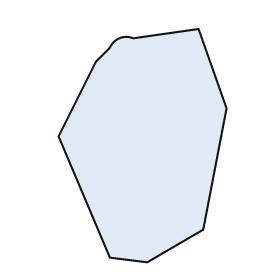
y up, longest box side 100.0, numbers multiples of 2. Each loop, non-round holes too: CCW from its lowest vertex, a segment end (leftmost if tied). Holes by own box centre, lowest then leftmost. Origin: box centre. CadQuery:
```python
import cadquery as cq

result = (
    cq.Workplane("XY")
    .moveTo(2.0, -50.0)
    .lineTo(26.0, -36.0)
    .lineTo(36.0, 16.0)
    .lineTo(24.0, 50.0)
    .lineTo(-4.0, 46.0)
    .threePointArc((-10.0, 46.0), (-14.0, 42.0))
    .lineTo(-20.0, 36.0)
    .lineTo(-36.0, 4.0)
    .lineTo(-14.0, -48.0)
    .close()
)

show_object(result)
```